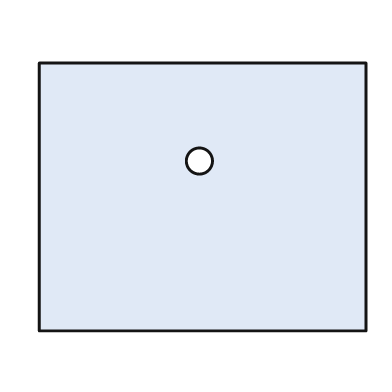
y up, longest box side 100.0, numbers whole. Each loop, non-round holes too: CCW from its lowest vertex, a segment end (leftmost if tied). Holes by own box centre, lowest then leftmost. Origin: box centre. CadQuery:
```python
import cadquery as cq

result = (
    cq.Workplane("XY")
    .moveTo(-50.0, -41.0)
    .lineTo(50.0, -41.0)
    .lineTo(50.0, 41.0)
    .lineTo(-50.0, 41.0)
    .close()
    .moveTo(-1.0, 11.0)
    .circle(4.0)
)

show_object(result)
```